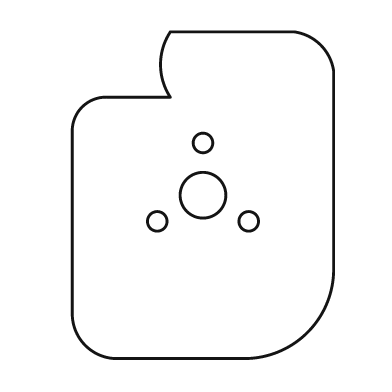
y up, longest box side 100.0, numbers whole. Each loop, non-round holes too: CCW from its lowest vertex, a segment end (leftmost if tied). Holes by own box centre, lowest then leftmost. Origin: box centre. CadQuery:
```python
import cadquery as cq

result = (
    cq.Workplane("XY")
    .moveTo(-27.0, -50.0)
    .lineTo(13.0, -50.0)
    .threePointArc((32.0, -42.0), (40.0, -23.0))
    .lineTo(40.0, 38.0)
    .threePointArc((36.0, 46.0), (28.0, 50.0))
    .lineTo(-10.0, 50.0)
    .threePointArc((-13.0, 40.0), (-10.0, 30.0))
    .lineTo(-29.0, 30.0)
    .threePointArc((-37.0, 27.0), (-40.0, 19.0))
    .lineTo(-40.0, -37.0)
    .threePointArc((-36.0, -46.0), (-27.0, -50.0))
    .close()
    .moveTo(-14.0, -8.0)
    .circle(3.0)
    .moveTo(14.0, -8.0)
    .circle(3.0)
    .moveTo(0.0, 0.0)
    .circle(7.0)
    .moveTo(0.0, 16.0)
    .circle(3.0)
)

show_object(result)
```